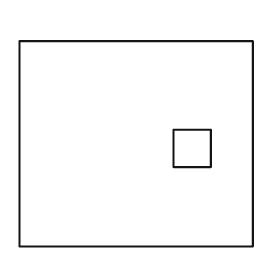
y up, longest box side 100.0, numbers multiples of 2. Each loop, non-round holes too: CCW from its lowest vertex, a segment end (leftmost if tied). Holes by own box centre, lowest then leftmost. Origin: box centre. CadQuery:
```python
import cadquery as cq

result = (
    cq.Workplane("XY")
    .moveTo(-50.0, -44.0)
    .lineTo(50.0, -44.0)
    .lineTo(50.0, 44.0)
    .lineTo(-50.0, 44.0)
    .close()
    .moveTo(16.0, -10.0)
    .lineTo(32.0, -10.0)
    .lineTo(32.0, 6.0)
    .lineTo(16.0, 6.0)
    .close()
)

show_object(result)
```